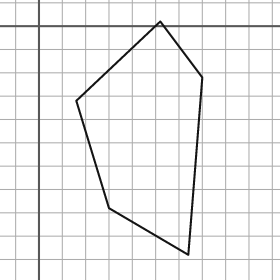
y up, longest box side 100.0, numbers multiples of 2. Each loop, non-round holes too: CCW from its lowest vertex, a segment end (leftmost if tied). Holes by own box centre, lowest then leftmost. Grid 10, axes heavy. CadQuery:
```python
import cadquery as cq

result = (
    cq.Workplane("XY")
    .moveTo(64.0, -98.0)
    .lineTo(70.0, -22.0)
    .lineTo(52.0, 2.0)
    .lineTo(16.0, -32.0)
    .lineTo(30.0, -78.0)
    .close()
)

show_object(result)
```